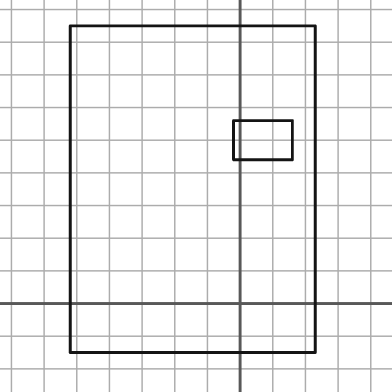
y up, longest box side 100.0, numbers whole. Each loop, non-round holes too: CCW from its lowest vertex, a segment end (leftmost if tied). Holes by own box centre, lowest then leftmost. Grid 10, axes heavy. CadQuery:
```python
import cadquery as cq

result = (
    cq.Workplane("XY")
    .moveTo(-52.0, -15.0)
    .lineTo(23.0, -15.0)
    .lineTo(23.0, 85.0)
    .lineTo(-52.0, 85.0)
    .close()
    .moveTo(-2.0, 44.0)
    .lineTo(16.0, 44.0)
    .lineTo(16.0, 56.0)
    .lineTo(-2.0, 56.0)
    .close()
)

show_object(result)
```